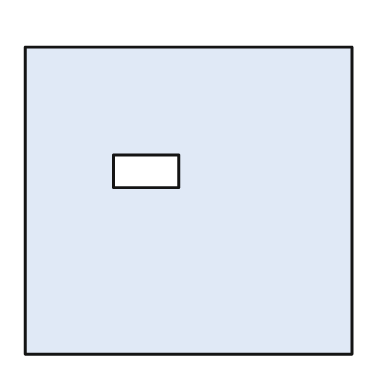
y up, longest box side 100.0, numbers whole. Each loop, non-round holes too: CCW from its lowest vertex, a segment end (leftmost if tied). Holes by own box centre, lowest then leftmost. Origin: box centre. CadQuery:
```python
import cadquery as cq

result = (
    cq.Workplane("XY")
    .moveTo(-50.0, -47.0)
    .lineTo(50.0, -47.0)
    .lineTo(50.0, 47.0)
    .lineTo(-50.0, 47.0)
    .close()
    .moveTo(-23.0, 4.0)
    .lineTo(-3.0, 4.0)
    .lineTo(-3.0, 14.0)
    .lineTo(-23.0, 14.0)
    .close()
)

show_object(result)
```